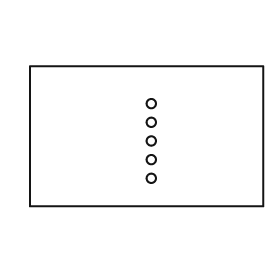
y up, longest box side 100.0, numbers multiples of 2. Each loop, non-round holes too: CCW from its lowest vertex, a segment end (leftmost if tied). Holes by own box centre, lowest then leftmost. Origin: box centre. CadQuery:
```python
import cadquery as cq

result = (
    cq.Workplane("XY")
    .moveTo(-50.0, -30.0)
    .lineTo(50.0, -30.0)
    .lineTo(50.0, 30.0)
    .lineTo(-50.0, 30.0)
    .close()
    .moveTo(2.0, -18.0)
    .circle(2.0)
    .moveTo(2.0, -10.0)
    .circle(2.0)
    .moveTo(2.0, -2.0)
    .circle(2.0)
    .moveTo(2.0, 6.0)
    .circle(2.0)
    .moveTo(2.0, 14.0)
    .circle(2.0)
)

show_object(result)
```